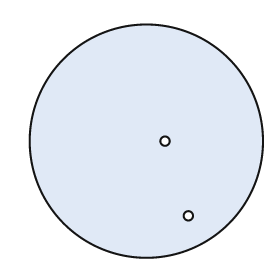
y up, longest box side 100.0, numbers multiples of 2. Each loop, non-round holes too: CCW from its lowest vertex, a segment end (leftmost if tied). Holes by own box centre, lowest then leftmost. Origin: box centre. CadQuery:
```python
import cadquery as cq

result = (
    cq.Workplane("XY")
    .moveTo(0.0, 0.0)
    .circle(50.0)
    .moveTo(18.0, -32.0)
    .circle(2.0)
    .moveTo(8.0, 0.0)
    .circle(2.0)
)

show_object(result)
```